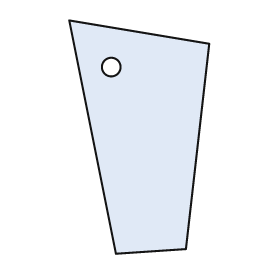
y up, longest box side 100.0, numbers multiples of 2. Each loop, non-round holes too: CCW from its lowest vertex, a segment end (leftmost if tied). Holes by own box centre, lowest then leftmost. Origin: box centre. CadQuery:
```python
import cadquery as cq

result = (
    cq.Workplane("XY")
    .moveTo(-10.0, -50.0)
    .lineTo(20.0, -48.0)
    .lineTo(30.0, 40.0)
    .lineTo(-30.0, 50.0)
    .close()
    .moveTo(-12.0, 30.0)
    .circle(4.0)
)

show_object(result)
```